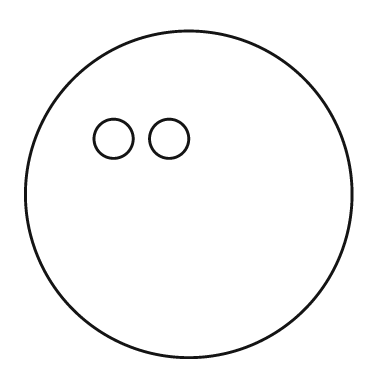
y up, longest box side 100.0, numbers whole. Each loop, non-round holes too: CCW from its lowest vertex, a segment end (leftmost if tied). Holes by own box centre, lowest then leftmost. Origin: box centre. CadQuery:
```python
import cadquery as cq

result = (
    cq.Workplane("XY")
    .moveTo(0.0, 0.0)
    .circle(50.0)
    .moveTo(-23.0, 17.0)
    .circle(6.0)
    .moveTo(-6.0, 17.0)
    .circle(6.0)
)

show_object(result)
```